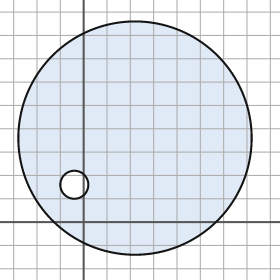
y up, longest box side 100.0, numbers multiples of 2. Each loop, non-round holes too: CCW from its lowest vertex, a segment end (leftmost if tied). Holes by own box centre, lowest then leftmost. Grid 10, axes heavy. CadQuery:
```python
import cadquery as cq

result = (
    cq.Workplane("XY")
    .moveTo(22.0, 36.0)
    .circle(50.0)
    .moveTo(-4.0, 16.0)
    .circle(6.0)
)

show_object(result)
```